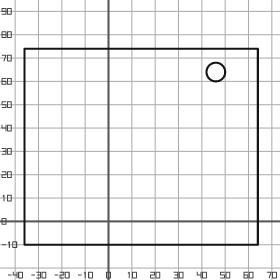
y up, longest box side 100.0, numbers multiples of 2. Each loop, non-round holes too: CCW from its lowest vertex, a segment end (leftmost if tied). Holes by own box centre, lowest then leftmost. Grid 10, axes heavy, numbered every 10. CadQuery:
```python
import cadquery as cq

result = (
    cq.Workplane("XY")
    .moveTo(-36.0, -10.0)
    .lineTo(64.0, -10.0)
    .lineTo(64.0, 74.0)
    .lineTo(-36.0, 74.0)
    .close()
    .moveTo(46.0, 64.0)
    .circle(4.0)
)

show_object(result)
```